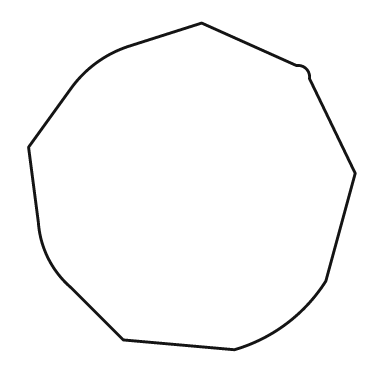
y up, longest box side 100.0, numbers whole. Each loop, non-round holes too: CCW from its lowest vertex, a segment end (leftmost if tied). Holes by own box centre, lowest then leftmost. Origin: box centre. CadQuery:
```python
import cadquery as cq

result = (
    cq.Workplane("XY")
    .moveTo(13.0, -50.0)
    .threePointArc((29.0, -42.0), (41.0, -29.0))
    .lineTo(50.0, 4.0)
    .lineTo(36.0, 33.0)
    .threePointArc((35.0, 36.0), (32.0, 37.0))
    .lineTo(3.0, 50.0)
    .lineTo(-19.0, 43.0)
    .threePointArc((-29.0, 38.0), (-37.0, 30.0))
    .lineTo(-50.0, 12.0)
    .lineTo(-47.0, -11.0)
    .threePointArc((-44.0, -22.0), (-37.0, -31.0))
    .lineTo(-21.0, -47.0)
    .close()
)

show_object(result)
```